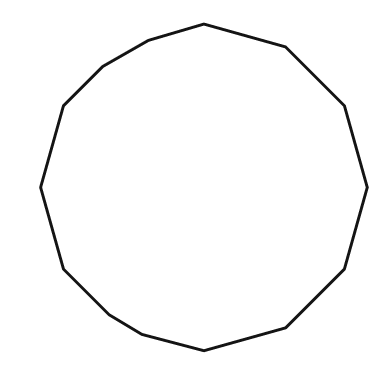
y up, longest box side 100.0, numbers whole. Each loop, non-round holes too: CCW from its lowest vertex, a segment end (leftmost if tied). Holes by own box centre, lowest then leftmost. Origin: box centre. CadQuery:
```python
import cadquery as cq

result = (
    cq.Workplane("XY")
    .moveTo(0.0, -50.0)
    .lineTo(25.0, -43.0)
    .lineTo(43.0, -25.0)
    .lineTo(50.0, 0.0)
    .lineTo(43.0, 25.0)
    .lineTo(25.0, 43.0)
    .lineTo(0.0, 50.0)
    .lineTo(-17.0, 45.0)
    .lineTo(-31.0, 37.0)
    .lineTo(-43.0, 25.0)
    .lineTo(-50.0, 0.0)
    .lineTo(-43.0, -25.0)
    .lineTo(-29.0, -39.0)
    .lineTo(-19.0, -45.0)
    .close()
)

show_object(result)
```